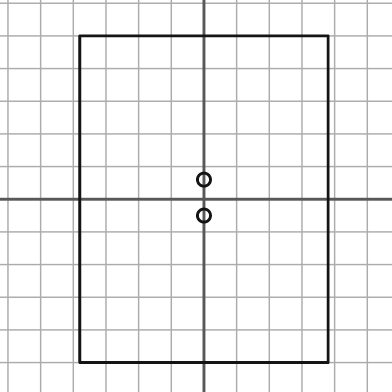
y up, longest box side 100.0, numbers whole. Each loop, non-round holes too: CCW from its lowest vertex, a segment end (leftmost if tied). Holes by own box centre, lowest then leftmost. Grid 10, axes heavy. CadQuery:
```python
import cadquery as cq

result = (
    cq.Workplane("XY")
    .moveTo(-38.0, -50.0)
    .lineTo(38.0, -50.0)
    .lineTo(38.0, 50.0)
    .lineTo(-38.0, 50.0)
    .close()
    .moveTo(0.0, -5.0)
    .circle(2.0)
    .moveTo(0.0, 6.0)
    .circle(2.0)
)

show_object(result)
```